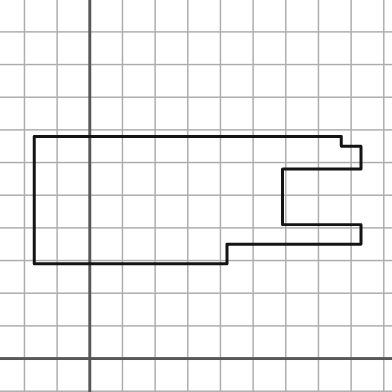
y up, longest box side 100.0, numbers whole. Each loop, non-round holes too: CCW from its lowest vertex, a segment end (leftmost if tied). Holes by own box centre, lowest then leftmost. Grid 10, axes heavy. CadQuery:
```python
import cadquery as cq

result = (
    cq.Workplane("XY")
    .moveTo(-17.0, 29.0)
    .lineTo(42.0, 29.0)
    .lineTo(42.0, 35.0)
    .lineTo(83.0, 35.0)
    .lineTo(83.0, 41.0)
    .lineTo(59.0, 41.0)
    .lineTo(59.0, 58.0)
    .lineTo(83.0, 58.0)
    .lineTo(83.0, 65.0)
    .lineTo(77.0, 65.0)
    .lineTo(77.0, 68.0)
    .lineTo(-17.0, 68.0)
    .close()
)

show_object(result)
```